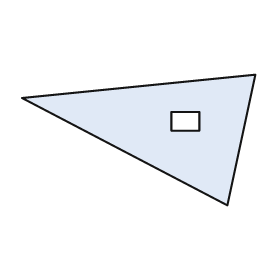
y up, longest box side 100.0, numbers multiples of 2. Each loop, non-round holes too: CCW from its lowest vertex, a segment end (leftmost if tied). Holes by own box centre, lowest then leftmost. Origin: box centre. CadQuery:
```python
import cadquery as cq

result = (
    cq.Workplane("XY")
    .moveTo(38.0, -28.0)
    .lineTo(50.0, 28.0)
    .lineTo(-50.0, 18.0)
    .close()
    .moveTo(14.0, 4.0)
    .lineTo(26.0, 4.0)
    .lineTo(26.0, 12.0)
    .lineTo(14.0, 12.0)
    .close()
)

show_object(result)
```